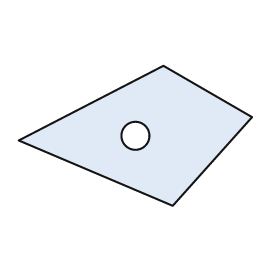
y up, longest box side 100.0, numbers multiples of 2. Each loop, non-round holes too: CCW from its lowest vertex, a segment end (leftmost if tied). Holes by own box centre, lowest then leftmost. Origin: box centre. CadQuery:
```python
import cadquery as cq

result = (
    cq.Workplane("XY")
    .moveTo(16.0, -30.0)
    .lineTo(50.0, 8.0)
    .lineTo(12.0, 30.0)
    .lineTo(-50.0, -2.0)
    .close()
    .moveTo(0.0, 0.0)
    .circle(6.0)
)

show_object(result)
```